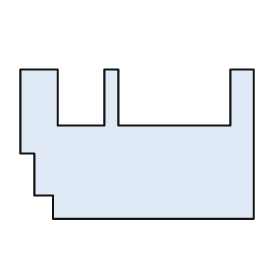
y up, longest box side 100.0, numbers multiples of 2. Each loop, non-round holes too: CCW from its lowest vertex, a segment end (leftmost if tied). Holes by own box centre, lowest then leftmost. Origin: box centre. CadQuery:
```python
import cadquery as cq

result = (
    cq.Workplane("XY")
    .moveTo(-36.0, -32.0)
    .lineTo(50.0, -32.0)
    .lineTo(50.0, 32.0)
    .lineTo(40.0, 32.0)
    .lineTo(40.0, 8.0)
    .lineTo(-8.0, 8.0)
    .lineTo(-8.0, 32.0)
    .lineTo(-14.0, 32.0)
    .lineTo(-14.0, 8.0)
    .lineTo(-34.0, 8.0)
    .lineTo(-34.0, 32.0)
    .lineTo(-50.0, 32.0)
    .lineTo(-50.0, -4.0)
    .lineTo(-44.0, -4.0)
    .lineTo(-44.0, -22.0)
    .lineTo(-36.0, -22.0)
    .close()
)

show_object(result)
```